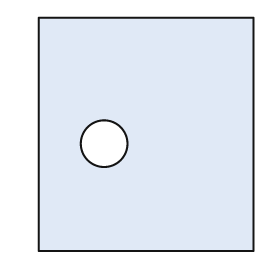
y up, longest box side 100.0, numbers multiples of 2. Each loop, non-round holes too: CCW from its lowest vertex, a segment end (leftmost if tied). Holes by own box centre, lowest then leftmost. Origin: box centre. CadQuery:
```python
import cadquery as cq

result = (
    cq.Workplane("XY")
    .moveTo(-46.0, -50.0)
    .lineTo(46.0, -50.0)
    .lineTo(46.0, 50.0)
    .lineTo(-46.0, 50.0)
    .close()
    .moveTo(-18.0, -4.0)
    .circle(10.0)
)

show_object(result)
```